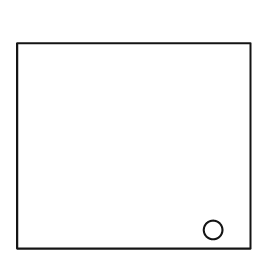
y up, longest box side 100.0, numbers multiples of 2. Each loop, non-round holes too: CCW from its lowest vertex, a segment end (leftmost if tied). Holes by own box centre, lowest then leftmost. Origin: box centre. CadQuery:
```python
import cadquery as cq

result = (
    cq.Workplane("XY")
    .moveTo(-50.0, -44.0)
    .lineTo(50.0, -44.0)
    .lineTo(50.0, 44.0)
    .lineTo(-50.0, 44.0)
    .close()
    .moveTo(34.0, -36.0)
    .circle(4.0)
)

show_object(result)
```